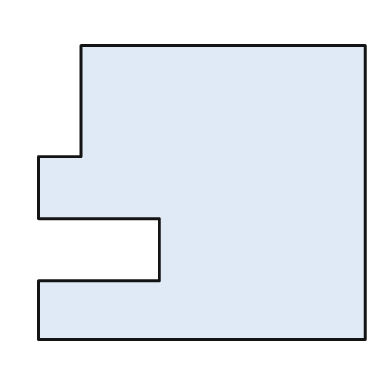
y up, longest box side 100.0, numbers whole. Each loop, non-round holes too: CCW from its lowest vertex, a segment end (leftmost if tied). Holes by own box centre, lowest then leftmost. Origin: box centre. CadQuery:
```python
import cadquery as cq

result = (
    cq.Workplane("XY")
    .moveTo(-50.0, -45.0)
    .lineTo(50.0, -45.0)
    .lineTo(50.0, 45.0)
    .lineTo(-37.0, 45.0)
    .lineTo(-37.0, 11.0)
    .lineTo(-50.0, 11.0)
    .lineTo(-50.0, -8.0)
    .lineTo(-13.0, -8.0)
    .lineTo(-13.0, -27.0)
    .lineTo(-50.0, -27.0)
    .close()
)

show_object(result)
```